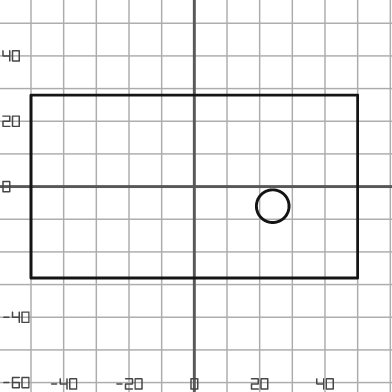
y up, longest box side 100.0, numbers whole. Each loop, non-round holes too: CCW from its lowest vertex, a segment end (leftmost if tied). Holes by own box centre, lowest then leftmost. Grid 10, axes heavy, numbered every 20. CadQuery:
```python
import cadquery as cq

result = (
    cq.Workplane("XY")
    .moveTo(-50.0, -28.0)
    .lineTo(50.0, -28.0)
    .lineTo(50.0, 28.0)
    .lineTo(-50.0, 28.0)
    .close()
    .moveTo(24.0, -6.0)
    .circle(5.0)
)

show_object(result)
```